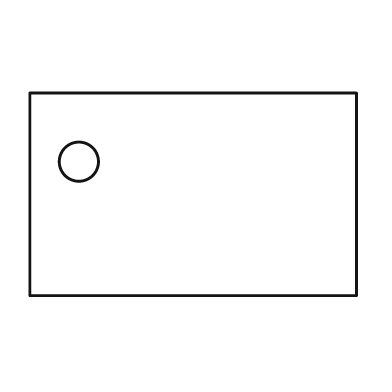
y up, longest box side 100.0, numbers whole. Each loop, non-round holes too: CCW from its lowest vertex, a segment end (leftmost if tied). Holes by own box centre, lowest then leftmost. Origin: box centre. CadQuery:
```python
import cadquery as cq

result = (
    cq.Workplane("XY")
    .moveTo(-50.0, -31.0)
    .lineTo(50.0, -31.0)
    .lineTo(50.0, 31.0)
    .lineTo(-50.0, 31.0)
    .close()
    .moveTo(-35.0, 10.0)
    .circle(6.0)
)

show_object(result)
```